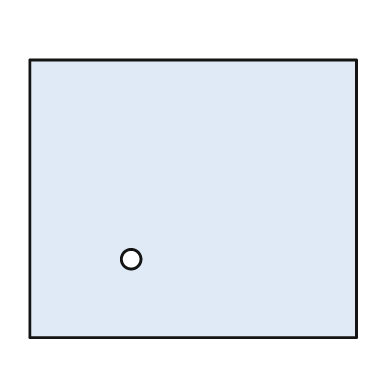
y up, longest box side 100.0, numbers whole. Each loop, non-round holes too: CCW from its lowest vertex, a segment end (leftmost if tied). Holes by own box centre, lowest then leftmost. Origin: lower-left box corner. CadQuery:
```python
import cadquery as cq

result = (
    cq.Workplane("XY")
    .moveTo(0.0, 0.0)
    .lineTo(100.0, 0.0)
    .lineTo(100.0, 85.0)
    .lineTo(0.0, 85.0)
    .close()
    .moveTo(31.0, 24.0)
    .circle(3.0)
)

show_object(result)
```